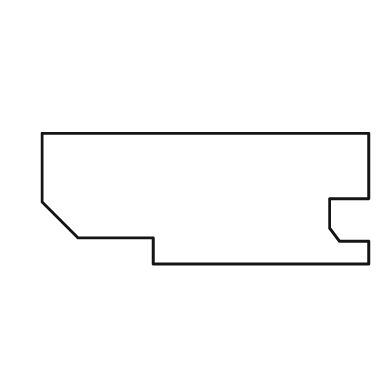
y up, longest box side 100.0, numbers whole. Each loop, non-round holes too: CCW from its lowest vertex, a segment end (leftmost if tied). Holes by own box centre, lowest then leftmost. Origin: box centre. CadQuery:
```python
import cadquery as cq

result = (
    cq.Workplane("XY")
    .moveTo(-16.0, -20.0)
    .lineTo(50.0, -20.0)
    .lineTo(50.0, -13.0)
    .lineTo(41.0, -13.0)
    .lineTo(38.0, -9.0)
    .lineTo(38.0, 0.0)
    .lineTo(50.0, 0.0)
    .lineTo(50.0, 20.0)
    .lineTo(-50.0, 20.0)
    .lineTo(-50.0, -1.0)
    .lineTo(-39.0, -12.0)
    .lineTo(-16.0, -12.0)
    .close()
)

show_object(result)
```